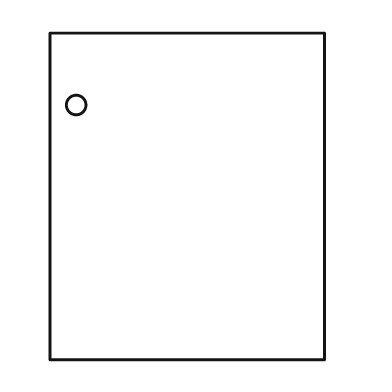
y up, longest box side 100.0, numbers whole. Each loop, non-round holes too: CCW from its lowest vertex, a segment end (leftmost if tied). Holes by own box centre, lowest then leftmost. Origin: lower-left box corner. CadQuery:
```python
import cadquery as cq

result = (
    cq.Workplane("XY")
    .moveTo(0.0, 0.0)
    .lineTo(84.0, 0.0)
    .lineTo(84.0, 100.0)
    .lineTo(0.0, 100.0)
    .close()
    .moveTo(8.0, 78.0)
    .circle(3.0)
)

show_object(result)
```